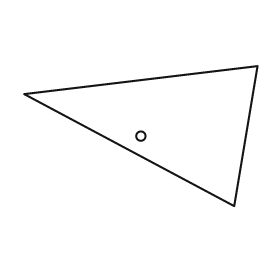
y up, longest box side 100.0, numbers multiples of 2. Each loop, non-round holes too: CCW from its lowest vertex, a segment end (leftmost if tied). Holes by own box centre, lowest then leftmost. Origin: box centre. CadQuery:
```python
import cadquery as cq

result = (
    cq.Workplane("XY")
    .moveTo(40.0, -30.0)
    .lineTo(50.0, 30.0)
    .lineTo(-50.0, 18.0)
    .close()
    .moveTo(0.0, 0.0)
    .circle(2.0)
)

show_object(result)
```